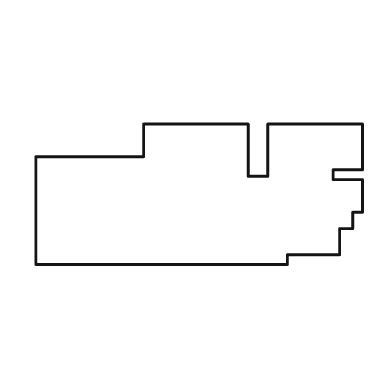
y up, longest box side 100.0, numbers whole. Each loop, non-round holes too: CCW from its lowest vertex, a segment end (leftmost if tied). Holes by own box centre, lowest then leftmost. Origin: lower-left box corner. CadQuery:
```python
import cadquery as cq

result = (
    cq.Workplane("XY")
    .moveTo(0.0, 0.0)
    .lineTo(77.0, 0.0)
    .lineTo(77.0, 3.0)
    .lineTo(93.0, 3.0)
    .lineTo(93.0, 11.0)
    .lineTo(97.0, 11.0)
    .lineTo(97.0, 16.0)
    .lineTo(100.0, 16.0)
    .lineTo(100.0, 26.0)
    .lineTo(91.0, 26.0)
    .lineTo(91.0, 29.0)
    .lineTo(100.0, 29.0)
    .lineTo(100.0, 43.0)
    .lineTo(71.0, 43.0)
    .lineTo(71.0, 27.0)
    .lineTo(65.0, 27.0)
    .lineTo(65.0, 43.0)
    .lineTo(33.0, 43.0)
    .lineTo(33.0, 33.0)
    .lineTo(0.0, 33.0)
    .close()
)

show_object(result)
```